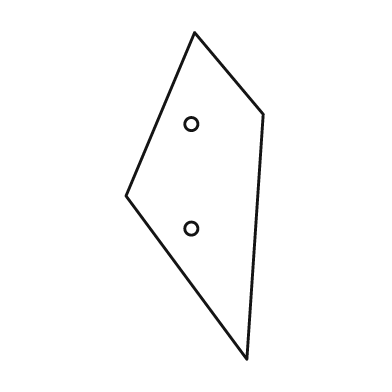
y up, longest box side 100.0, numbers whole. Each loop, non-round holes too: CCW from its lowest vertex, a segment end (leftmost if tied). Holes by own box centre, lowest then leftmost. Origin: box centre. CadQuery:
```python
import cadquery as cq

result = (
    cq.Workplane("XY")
    .moveTo(16.0, -50.0)
    .lineTo(21.0, 25.0)
    .lineTo(0.0, 50.0)
    .lineTo(-21.0, 0.0)
    .close()
    .moveTo(-1.0, -10.0)
    .circle(2.0)
    .moveTo(-1.0, 22.0)
    .circle(2.0)
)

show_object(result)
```